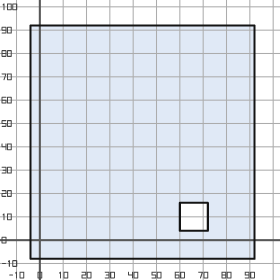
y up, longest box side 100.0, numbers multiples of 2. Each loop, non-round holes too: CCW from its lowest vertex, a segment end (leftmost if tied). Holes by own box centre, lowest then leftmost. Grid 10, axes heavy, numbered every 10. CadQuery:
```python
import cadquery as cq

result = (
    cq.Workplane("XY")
    .moveTo(-4.0, -8.0)
    .lineTo(92.0, -8.0)
    .lineTo(92.0, 92.0)
    .lineTo(-4.0, 92.0)
    .close()
    .moveTo(60.0, 4.0)
    .lineTo(72.0, 4.0)
    .lineTo(72.0, 16.0)
    .lineTo(60.0, 16.0)
    .close()
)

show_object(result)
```